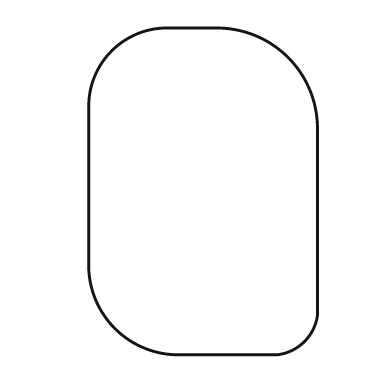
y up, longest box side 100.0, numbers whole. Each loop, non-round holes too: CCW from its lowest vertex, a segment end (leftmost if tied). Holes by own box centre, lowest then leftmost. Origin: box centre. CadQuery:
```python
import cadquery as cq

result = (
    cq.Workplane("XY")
    .moveTo(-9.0, -50.0)
    .lineTo(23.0, -50.0)
    .threePointArc((31.0, -46.0), (35.0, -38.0))
    .lineTo(35.0, 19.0)
    .threePointArc((26.0, 41.0), (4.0, 50.0))
    .lineTo(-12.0, 50.0)
    .threePointArc((-28.0, 43.0), (-35.0, 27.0))
    .lineTo(-35.0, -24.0)
    .threePointArc((-27.0, -42.0), (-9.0, -50.0))
    .close()
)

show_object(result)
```